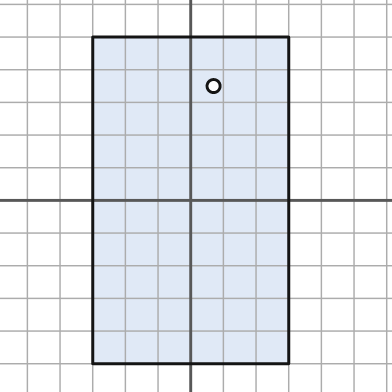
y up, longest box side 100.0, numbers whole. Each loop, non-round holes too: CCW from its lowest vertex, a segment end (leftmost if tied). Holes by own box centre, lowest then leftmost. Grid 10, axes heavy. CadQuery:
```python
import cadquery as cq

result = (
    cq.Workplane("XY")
    .moveTo(-30.0, -50.0)
    .lineTo(30.0, -50.0)
    .lineTo(30.0, 50.0)
    .lineTo(-30.0, 50.0)
    .close()
    .moveTo(7.0, 35.0)
    .circle(2.0)
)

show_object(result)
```